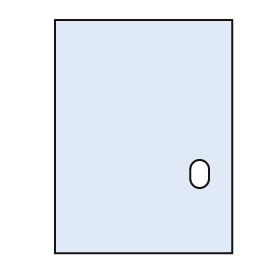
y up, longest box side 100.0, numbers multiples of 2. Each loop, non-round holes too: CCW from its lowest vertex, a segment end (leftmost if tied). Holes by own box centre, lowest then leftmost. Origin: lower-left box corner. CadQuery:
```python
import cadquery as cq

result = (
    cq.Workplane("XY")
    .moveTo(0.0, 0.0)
    .lineTo(76.0, 0.0)
    .lineTo(76.0, 100.0)
    .lineTo(0.0, 100.0)
    .close()
    .moveTo(58.0, 32.0)
    .threePointArc((62.0, 28.0), (66.0, 32.0))
    .lineTo(66.0, 36.0)
    .threePointArc((62.0, 40.0), (58.0, 36.0))
    .close()
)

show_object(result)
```